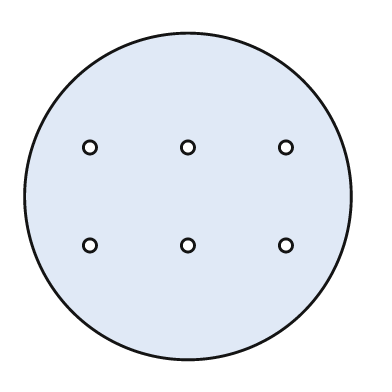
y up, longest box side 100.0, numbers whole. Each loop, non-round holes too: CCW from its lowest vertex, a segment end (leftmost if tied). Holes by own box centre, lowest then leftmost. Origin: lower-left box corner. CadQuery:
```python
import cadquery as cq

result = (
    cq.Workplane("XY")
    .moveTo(50.0, 50.0)
    .circle(50.0)
    .moveTo(20.0, 35.0)
    .circle(2.0)
    .moveTo(50.0, 35.0)
    .circle(2.0)
    .moveTo(80.0, 35.0)
    .circle(2.0)
    .moveTo(20.0, 65.0)
    .circle(2.0)
    .moveTo(50.0, 65.0)
    .circle(2.0)
    .moveTo(80.0, 65.0)
    .circle(2.0)
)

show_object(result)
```